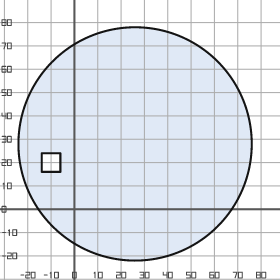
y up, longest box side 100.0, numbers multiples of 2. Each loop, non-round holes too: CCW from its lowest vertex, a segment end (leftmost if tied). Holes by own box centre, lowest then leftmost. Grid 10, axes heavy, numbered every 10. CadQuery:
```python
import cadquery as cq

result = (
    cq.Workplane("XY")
    .moveTo(26.0, 28.0)
    .circle(50.0)
    .moveTo(-14.0, 16.0)
    .lineTo(-6.0, 16.0)
    .lineTo(-6.0, 24.0)
    .lineTo(-14.0, 24.0)
    .close()
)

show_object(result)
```